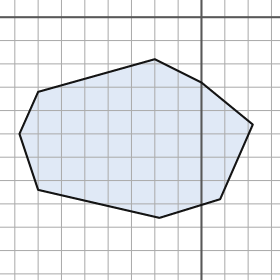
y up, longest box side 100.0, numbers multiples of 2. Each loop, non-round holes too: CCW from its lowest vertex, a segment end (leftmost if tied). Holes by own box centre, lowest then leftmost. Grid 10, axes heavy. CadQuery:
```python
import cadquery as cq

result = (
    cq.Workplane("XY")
    .moveTo(-18.0, -86.0)
    .lineTo(8.0, -78.0)
    .lineTo(22.0, -46.0)
    .lineTo(0.0, -28.0)
    .lineTo(-20.0, -18.0)
    .lineTo(-70.0, -32.0)
    .lineTo(-78.0, -50.0)
    .lineTo(-70.0, -74.0)
    .close()
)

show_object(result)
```